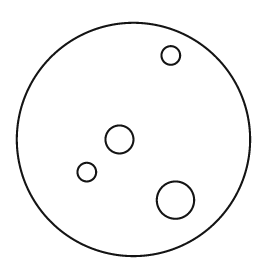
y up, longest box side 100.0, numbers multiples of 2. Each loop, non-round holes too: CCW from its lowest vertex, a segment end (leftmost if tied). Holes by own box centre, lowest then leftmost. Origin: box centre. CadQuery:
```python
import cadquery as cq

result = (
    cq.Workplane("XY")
    .moveTo(0.0, 0.0)
    .circle(50.0)
    .moveTo(18.0, -26.0)
    .circle(8.0)
    .moveTo(-20.0, -14.0)
    .circle(4.0)
    .moveTo(-6.0, 0.0)
    .circle(6.0)
    .moveTo(16.0, 36.0)
    .circle(4.0)
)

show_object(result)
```